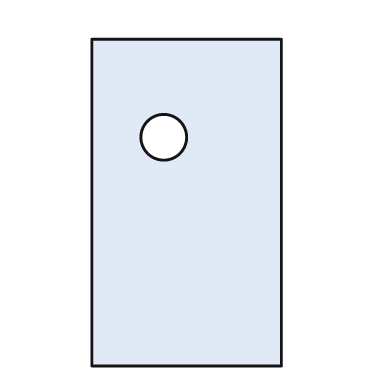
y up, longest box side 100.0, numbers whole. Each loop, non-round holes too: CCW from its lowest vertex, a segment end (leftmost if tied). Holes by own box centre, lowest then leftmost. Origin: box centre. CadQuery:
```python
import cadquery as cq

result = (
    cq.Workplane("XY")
    .moveTo(-29.0, -50.0)
    .lineTo(29.0, -50.0)
    .lineTo(29.0, 50.0)
    .lineTo(-29.0, 50.0)
    .close()
    .moveTo(-7.0, 20.0)
    .circle(7.0)
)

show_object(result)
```